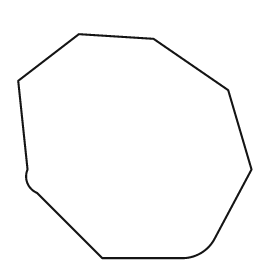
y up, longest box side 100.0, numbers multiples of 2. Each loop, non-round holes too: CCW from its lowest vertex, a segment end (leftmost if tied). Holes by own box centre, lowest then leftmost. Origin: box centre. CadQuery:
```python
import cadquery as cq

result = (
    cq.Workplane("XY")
    .moveTo(-14.0, -48.0)
    .lineTo(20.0, -48.0)
    .threePointArc((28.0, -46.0), (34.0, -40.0))
    .lineTo(50.0, -10.0)
    .lineTo(40.0, 24.0)
    .lineTo(8.0, 46.0)
    .lineTo(-24.0, 48.0)
    .lineTo(-50.0, 28.0)
    .lineTo(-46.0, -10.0)
    .threePointArc((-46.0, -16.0), (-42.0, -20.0))
    .close()
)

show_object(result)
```